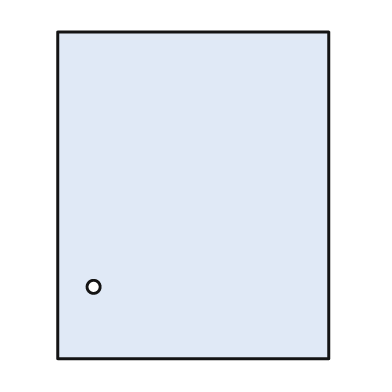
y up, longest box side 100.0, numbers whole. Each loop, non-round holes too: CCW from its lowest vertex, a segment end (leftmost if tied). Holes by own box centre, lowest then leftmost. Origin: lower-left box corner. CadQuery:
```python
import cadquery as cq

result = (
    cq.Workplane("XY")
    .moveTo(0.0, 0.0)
    .lineTo(83.0, 0.0)
    .lineTo(83.0, 100.0)
    .lineTo(0.0, 100.0)
    .close()
    .moveTo(11.0, 22.0)
    .circle(2.0)
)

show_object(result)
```